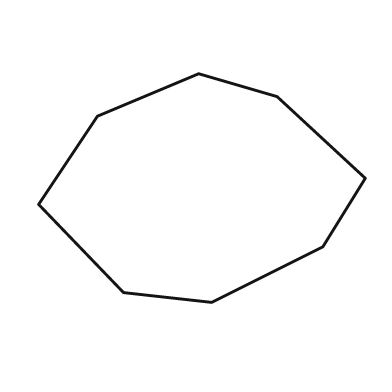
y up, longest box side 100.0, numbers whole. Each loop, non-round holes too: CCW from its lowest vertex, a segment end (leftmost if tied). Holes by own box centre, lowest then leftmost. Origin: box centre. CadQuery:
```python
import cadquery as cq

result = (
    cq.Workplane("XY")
    .moveTo(3.0, -35.0)
    .lineTo(37.0, -18.0)
    .lineTo(50.0, 3.0)
    .lineTo(23.0, 28.0)
    .lineTo(-1.0, 35.0)
    .lineTo(-32.0, 22.0)
    .lineTo(-50.0, -5.0)
    .lineTo(-24.0, -32.0)
    .close()
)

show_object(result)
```